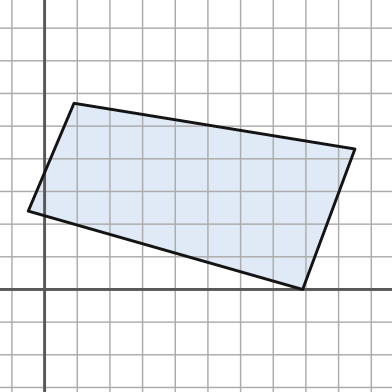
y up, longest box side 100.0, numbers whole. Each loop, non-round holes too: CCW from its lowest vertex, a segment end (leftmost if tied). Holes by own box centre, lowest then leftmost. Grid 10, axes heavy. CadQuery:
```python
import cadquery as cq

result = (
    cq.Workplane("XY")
    .moveTo(79.0, 0.0)
    .lineTo(95.0, 43.0)
    .lineTo(9.0, 57.0)
    .lineTo(-5.0, 24.0)
    .close()
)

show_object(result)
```